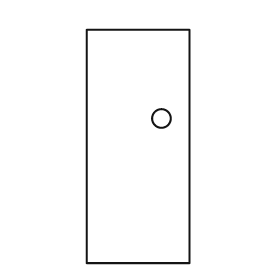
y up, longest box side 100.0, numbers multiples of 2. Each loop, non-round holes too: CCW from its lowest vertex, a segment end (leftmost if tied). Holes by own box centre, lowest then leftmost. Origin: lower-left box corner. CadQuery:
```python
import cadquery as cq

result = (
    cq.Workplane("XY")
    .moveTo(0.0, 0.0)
    .lineTo(44.0, 0.0)
    .lineTo(44.0, 100.0)
    .lineTo(0.0, 100.0)
    .close()
    .moveTo(32.0, 62.0)
    .circle(4.0)
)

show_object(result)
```